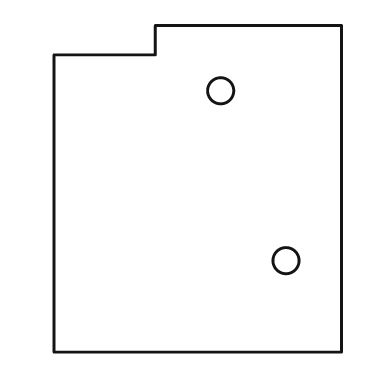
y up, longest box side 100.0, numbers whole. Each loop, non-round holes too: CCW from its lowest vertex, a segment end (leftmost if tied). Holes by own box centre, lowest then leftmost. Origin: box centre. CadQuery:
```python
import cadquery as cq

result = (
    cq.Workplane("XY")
    .moveTo(-44.0, -50.0)
    .lineTo(44.0, -50.0)
    .lineTo(44.0, 50.0)
    .lineTo(-13.0, 50.0)
    .lineTo(-13.0, 41.0)
    .lineTo(-44.0, 41.0)
    .close()
    .moveTo(27.0, -22.0)
    .circle(4.0)
    .moveTo(7.0, 30.0)
    .circle(4.0)
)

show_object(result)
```